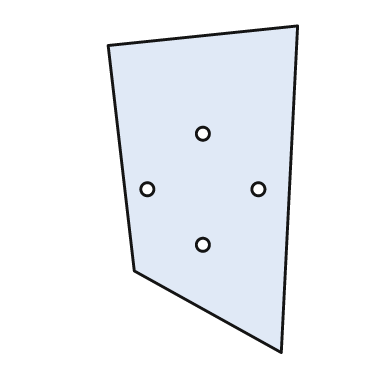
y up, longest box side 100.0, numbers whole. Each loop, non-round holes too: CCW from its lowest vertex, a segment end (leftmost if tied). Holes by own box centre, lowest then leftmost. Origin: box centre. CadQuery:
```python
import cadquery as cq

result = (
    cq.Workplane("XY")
    .moveTo(24.0, -50.0)
    .lineTo(29.0, 50.0)
    .lineTo(-29.0, 44.0)
    .lineTo(-21.0, -25.0)
    .close()
    .moveTo(0.0, -17.0)
    .circle(2.0)
    .moveTo(-17.0, 0.0)
    .circle(2.0)
    .moveTo(17.0, 0.0)
    .circle(2.0)
    .moveTo(0.0, 17.0)
    .circle(2.0)
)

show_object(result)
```